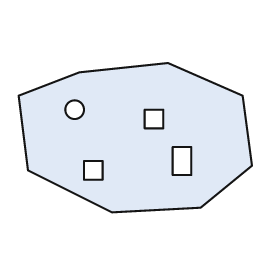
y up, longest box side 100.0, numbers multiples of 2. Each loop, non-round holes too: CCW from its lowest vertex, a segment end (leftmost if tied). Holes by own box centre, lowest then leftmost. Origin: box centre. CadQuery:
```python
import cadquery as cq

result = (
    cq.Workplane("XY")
    .moveTo(-10.0, -32.0)
    .lineTo(28.0, -30.0)
    .lineTo(50.0, -12.0)
    .lineTo(46.0, 18.0)
    .lineTo(14.0, 32.0)
    .lineTo(-24.0, 28.0)
    .lineTo(-50.0, 18.0)
    .lineTo(-46.0, -14.0)
    .close()
    .moveTo(-22.0, -18.0)
    .lineTo(-14.0, -18.0)
    .lineTo(-14.0, -10.0)
    .lineTo(-22.0, -10.0)
    .close()
    .moveTo(16.0, -16.0)
    .lineTo(24.0, -16.0)
    .lineTo(24.0, -4.0)
    .lineTo(16.0, -4.0)
    .close()
    .moveTo(4.0, 4.0)
    .lineTo(12.0, 4.0)
    .lineTo(12.0, 12.0)
    .lineTo(4.0, 12.0)
    .close()
    .moveTo(-26.0, 12.0)
    .circle(4.0)
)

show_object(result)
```